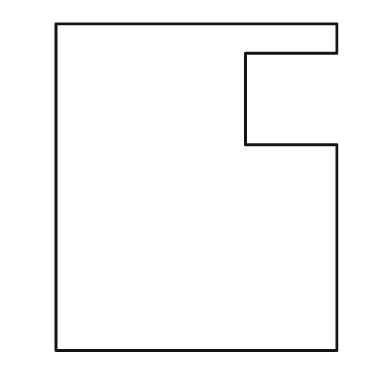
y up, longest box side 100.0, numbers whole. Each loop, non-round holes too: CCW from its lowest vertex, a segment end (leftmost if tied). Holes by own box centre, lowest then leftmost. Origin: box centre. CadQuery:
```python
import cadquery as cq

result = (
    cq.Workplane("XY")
    .moveTo(-43.0, -50.0)
    .lineTo(43.0, -50.0)
    .lineTo(43.0, 13.0)
    .lineTo(15.0, 13.0)
    .lineTo(15.0, 41.0)
    .lineTo(43.0, 41.0)
    .lineTo(43.0, 50.0)
    .lineTo(-43.0, 50.0)
    .close()
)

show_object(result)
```